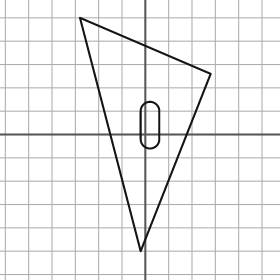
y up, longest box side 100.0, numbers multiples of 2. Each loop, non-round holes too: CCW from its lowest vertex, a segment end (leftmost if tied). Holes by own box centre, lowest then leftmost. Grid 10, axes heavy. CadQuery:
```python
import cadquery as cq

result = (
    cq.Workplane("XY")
    .moveTo(-2.0, -50.0)
    .lineTo(28.0, 26.0)
    .lineTo(-28.0, 50.0)
    .close()
    .moveTo(-2.0, -2.0)
    .threePointArc((2.0, -6.0), (6.0, -2.0))
    .lineTo(6.0, 10.0)
    .threePointArc((2.0, 14.0), (-2.0, 10.0))
    .close()
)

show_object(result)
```